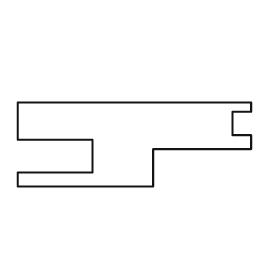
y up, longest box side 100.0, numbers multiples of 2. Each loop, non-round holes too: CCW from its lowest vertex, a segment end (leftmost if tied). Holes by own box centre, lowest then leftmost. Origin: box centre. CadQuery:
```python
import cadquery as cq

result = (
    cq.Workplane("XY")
    .moveTo(-50.0, -18.0)
    .lineTo(8.0, -18.0)
    .lineTo(8.0, -2.0)
    .lineTo(50.0, -2.0)
    .lineTo(50.0, 4.0)
    .lineTo(42.0, 4.0)
    .lineTo(42.0, 14.0)
    .lineTo(50.0, 14.0)
    .lineTo(50.0, 18.0)
    .lineTo(-50.0, 18.0)
    .lineTo(-50.0, 2.0)
    .lineTo(-18.0, 2.0)
    .lineTo(-18.0, -12.0)
    .lineTo(-50.0, -12.0)
    .close()
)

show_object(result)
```